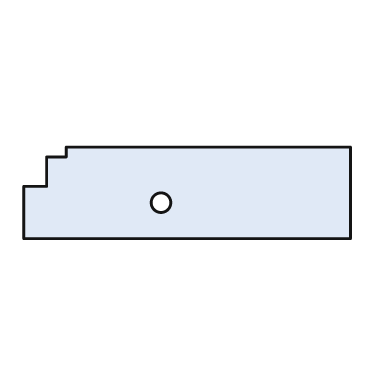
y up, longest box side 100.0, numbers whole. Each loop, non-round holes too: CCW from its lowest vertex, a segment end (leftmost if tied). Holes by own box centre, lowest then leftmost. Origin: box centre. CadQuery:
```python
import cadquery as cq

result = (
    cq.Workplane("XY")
    .moveTo(-50.0, -14.0)
    .lineTo(50.0, -14.0)
    .lineTo(50.0, 14.0)
    .lineTo(-37.0, 14.0)
    .lineTo(-37.0, 11.0)
    .lineTo(-43.0, 11.0)
    .lineTo(-43.0, 2.0)
    .lineTo(-50.0, 2.0)
    .close()
    .moveTo(-8.0, -3.0)
    .circle(3.0)
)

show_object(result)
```